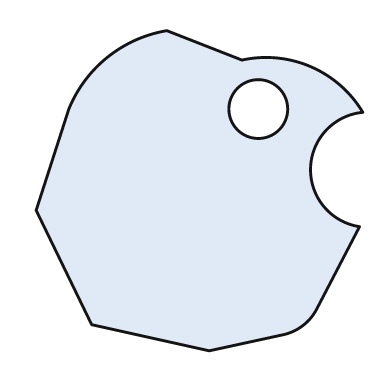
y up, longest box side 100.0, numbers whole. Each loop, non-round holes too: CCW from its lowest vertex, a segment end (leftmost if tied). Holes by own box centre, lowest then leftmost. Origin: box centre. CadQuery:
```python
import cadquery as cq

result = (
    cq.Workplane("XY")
    .moveTo(3.0, -49.0)
    .lineTo(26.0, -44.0)
    .threePointArc((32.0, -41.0), (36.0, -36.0))
    .lineTo(49.0, -11.0)
    .threePointArc((34.0, 7.0), (50.0, 24.0))
    .threePointArc((34.0, 38.0), (13.0, 40.0))
    .lineTo(-10.0, 49.0)
    .threePointArc((-28.0, 41.0), (-40.0, 25.0))
    .lineTo(-50.0, -6.0)
    .lineTo(-33.0, -41.0)
    .close()
    .moveTo(18.0, 25.0)
    .circle(9.0)
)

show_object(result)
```